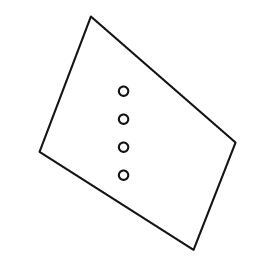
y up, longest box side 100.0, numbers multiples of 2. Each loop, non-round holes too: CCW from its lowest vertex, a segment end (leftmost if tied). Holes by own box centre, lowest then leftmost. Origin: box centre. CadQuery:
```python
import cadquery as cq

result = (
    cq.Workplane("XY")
    .moveTo(24.0, -50.0)
    .lineTo(42.0, -4.0)
    .lineTo(-20.0, 50.0)
    .lineTo(-42.0, -8.0)
    .close()
    .moveTo(-6.0, -18.0)
    .circle(2.0)
    .moveTo(-6.0, -6.0)
    .circle(2.0)
    .moveTo(-6.0, 6.0)
    .circle(2.0)
    .moveTo(-6.0, 18.0)
    .circle(2.0)
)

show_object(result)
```